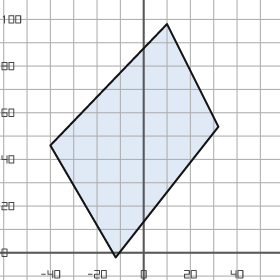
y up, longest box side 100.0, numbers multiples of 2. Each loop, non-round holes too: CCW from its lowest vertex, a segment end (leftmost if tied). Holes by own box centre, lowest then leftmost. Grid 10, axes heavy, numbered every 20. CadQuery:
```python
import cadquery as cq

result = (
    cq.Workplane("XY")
    .moveTo(-12.0, -2.0)
    .lineTo(32.0, 54.0)
    .lineTo(10.0, 98.0)
    .lineTo(-40.0, 46.0)
    .close()
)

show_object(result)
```